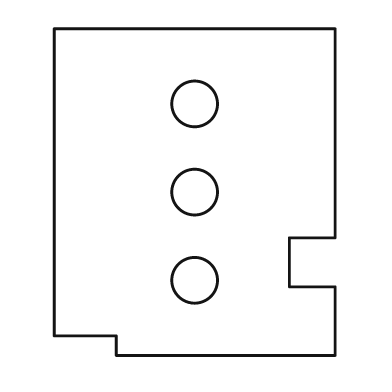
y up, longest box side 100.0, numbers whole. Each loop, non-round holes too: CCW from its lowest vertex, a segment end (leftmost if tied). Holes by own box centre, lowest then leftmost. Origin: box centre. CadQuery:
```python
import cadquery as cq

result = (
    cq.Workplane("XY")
    .moveTo(-24.0, -50.0)
    .lineTo(43.0, -50.0)
    .lineTo(43.0, -29.0)
    .lineTo(29.0, -29.0)
    .lineTo(29.0, -14.0)
    .lineTo(43.0, -14.0)
    .lineTo(43.0, 50.0)
    .lineTo(-43.0, 50.0)
    .lineTo(-43.0, -44.0)
    .lineTo(-24.0, -44.0)
    .close()
    .moveTo(0.0, -27.0)
    .circle(7.0)
    .moveTo(0.0, 0.0)
    .circle(7.0)
    .moveTo(0.0, 27.0)
    .circle(7.0)
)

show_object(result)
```